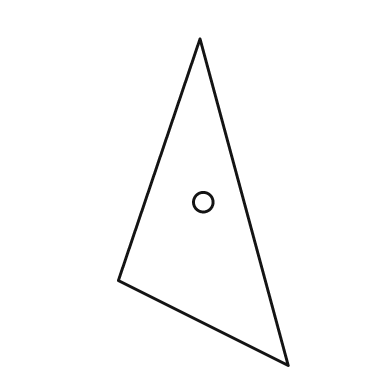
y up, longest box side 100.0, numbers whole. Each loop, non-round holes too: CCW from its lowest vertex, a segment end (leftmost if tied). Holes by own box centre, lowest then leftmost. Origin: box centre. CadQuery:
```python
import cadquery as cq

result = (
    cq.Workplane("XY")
    .moveTo(26.0, -50.0)
    .lineTo(-1.0, 50.0)
    .lineTo(-26.0, -24.0)
    .close()
    .moveTo(0.0, 0.0)
    .circle(3.0)
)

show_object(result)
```